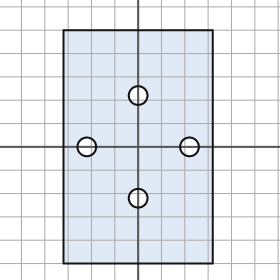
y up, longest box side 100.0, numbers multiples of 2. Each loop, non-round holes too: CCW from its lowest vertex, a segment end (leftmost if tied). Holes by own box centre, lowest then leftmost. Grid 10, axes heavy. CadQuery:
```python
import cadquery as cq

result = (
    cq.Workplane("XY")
    .moveTo(-32.0, -50.0)
    .lineTo(32.0, -50.0)
    .lineTo(32.0, 50.0)
    .lineTo(-32.0, 50.0)
    .close()
    .moveTo(0.0, -22.0)
    .circle(4.0)
    .moveTo(-22.0, 0.0)
    .circle(4.0)
    .moveTo(22.0, 0.0)
    .circle(4.0)
    .moveTo(0.0, 22.0)
    .circle(4.0)
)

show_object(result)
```